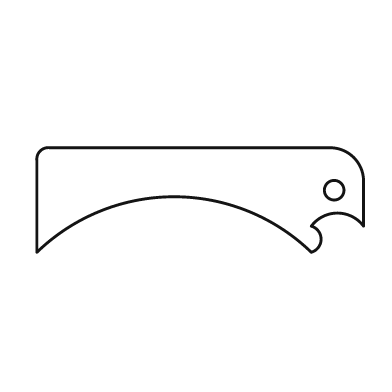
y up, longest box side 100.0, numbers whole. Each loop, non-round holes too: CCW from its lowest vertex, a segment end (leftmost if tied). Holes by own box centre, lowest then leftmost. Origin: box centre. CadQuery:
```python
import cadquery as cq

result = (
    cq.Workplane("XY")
    .moveTo(-50.0, -16.0)
    .threePointArc((-8.0, 1.0), (34.0, -16.0))
    .threePointArc((37.0, -12.0), (34.0, -8.0))
    .threePointArc((42.0, -4.0), (50.0, -8.0))
    .lineTo(50.0, 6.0)
    .threePointArc((47.0, 13.0), (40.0, 16.0))
    .lineTo(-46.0, 16.0)
    .threePointArc((-49.0, 15.0), (-50.0, 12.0))
    .close()
    .moveTo(41.0, 3.0)
    .circle(3.0)
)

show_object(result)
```